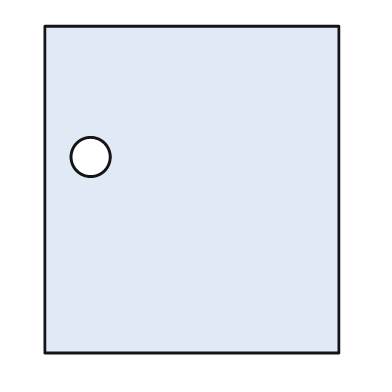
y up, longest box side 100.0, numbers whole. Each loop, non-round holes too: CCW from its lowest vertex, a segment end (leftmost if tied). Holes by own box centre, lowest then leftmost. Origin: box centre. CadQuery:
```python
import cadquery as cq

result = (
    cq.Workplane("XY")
    .moveTo(-45.0, -50.0)
    .lineTo(45.0, -50.0)
    .lineTo(45.0, 50.0)
    .lineTo(-45.0, 50.0)
    .close()
    .moveTo(-31.0, 10.0)
    .circle(6.0)
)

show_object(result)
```